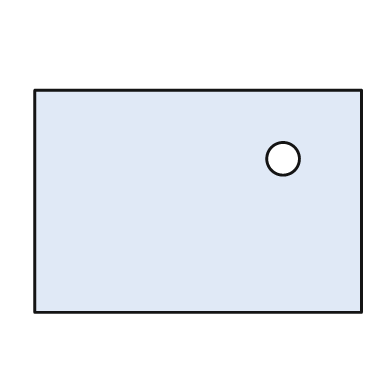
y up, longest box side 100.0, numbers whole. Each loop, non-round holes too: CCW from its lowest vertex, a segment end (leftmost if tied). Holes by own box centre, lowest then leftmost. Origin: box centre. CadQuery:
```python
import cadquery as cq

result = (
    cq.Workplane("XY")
    .moveTo(-50.0, -34.0)
    .lineTo(50.0, -34.0)
    .lineTo(50.0, 34.0)
    .lineTo(-50.0, 34.0)
    .close()
    .moveTo(26.0, 13.0)
    .circle(5.0)
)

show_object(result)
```